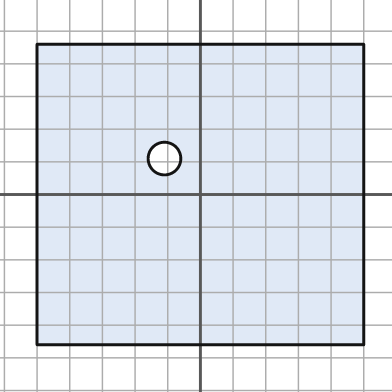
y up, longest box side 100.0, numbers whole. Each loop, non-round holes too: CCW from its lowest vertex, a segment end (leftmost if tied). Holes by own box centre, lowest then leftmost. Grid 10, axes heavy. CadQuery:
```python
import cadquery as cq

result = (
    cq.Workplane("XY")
    .moveTo(-50.0, -46.0)
    .lineTo(50.0, -46.0)
    .lineTo(50.0, 46.0)
    .lineTo(-50.0, 46.0)
    .close()
    .moveTo(-11.0, 11.0)
    .circle(5.0)
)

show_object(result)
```